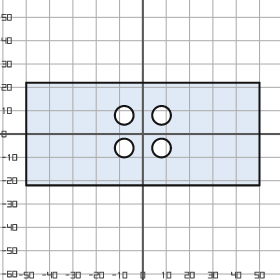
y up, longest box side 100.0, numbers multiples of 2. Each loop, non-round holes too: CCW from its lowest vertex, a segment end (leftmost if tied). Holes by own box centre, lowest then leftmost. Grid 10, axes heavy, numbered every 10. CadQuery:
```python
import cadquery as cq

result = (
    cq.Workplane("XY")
    .moveTo(-50.0, -22.0)
    .lineTo(50.0, -22.0)
    .lineTo(50.0, 22.0)
    .lineTo(-50.0, 22.0)
    .close()
    .moveTo(-8.0, -6.0)
    .circle(4.0)
    .moveTo(8.0, -6.0)
    .circle(4.0)
    .moveTo(-8.0, 8.0)
    .circle(4.0)
    .moveTo(8.0, 8.0)
    .circle(4.0)
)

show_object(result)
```